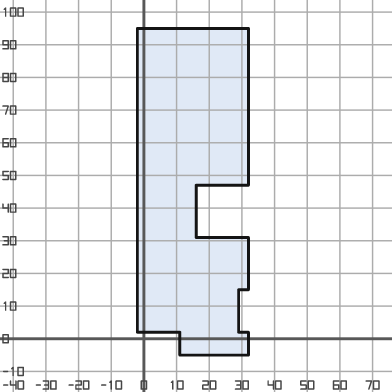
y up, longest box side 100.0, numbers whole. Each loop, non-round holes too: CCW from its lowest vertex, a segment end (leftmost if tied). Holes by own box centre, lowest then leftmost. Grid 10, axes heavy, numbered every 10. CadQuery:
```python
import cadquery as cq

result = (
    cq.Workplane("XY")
    .moveTo(11.0, -5.0)
    .lineTo(32.0, -5.0)
    .lineTo(32.0, 2.0)
    .lineTo(29.0, 2.0)
    .lineTo(29.0, 15.0)
    .lineTo(32.0, 15.0)
    .lineTo(32.0, 31.0)
    .lineTo(16.0, 31.0)
    .lineTo(16.0, 47.0)
    .lineTo(32.0, 47.0)
    .lineTo(32.0, 95.0)
    .lineTo(-2.0, 95.0)
    .lineTo(-2.0, 2.0)
    .lineTo(11.0, 2.0)
    .close()
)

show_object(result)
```